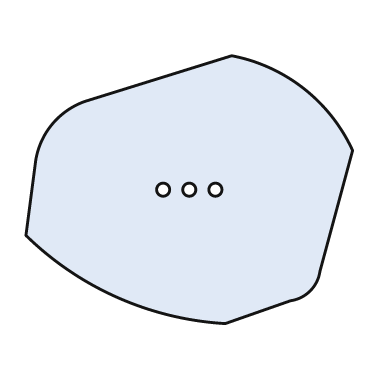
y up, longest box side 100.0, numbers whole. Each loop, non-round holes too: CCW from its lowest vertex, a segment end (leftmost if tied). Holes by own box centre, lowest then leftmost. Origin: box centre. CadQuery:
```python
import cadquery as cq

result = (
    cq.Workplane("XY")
    .moveTo(11.0, -41.0)
    .lineTo(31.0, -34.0)
    .threePointArc((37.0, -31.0), (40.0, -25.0))
    .lineTo(50.0, 12.0)
    .threePointArc((35.0, 31.0), (13.0, 41.0))
    .lineTo(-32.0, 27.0)
    .threePointArc((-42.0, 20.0), (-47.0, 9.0))
    .lineTo(-50.0, -14.0)
    .threePointArc((-22.0, -33.0), (11.0, -41.0))
    .close()
    .moveTo(-8.0, 0.0)
    .circle(2.0)
    .moveTo(0.0, 0.0)
    .circle(2.0)
    .moveTo(8.0, 0.0)
    .circle(2.0)
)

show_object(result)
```